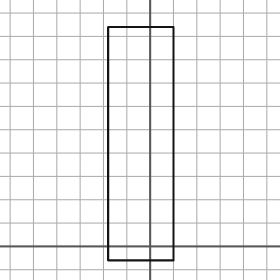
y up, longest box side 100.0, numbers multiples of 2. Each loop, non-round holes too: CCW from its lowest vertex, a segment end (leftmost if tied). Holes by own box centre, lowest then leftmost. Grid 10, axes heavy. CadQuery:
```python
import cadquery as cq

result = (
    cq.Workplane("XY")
    .moveTo(-18.0, -6.0)
    .lineTo(10.0, -6.0)
    .lineTo(10.0, 94.0)
    .lineTo(-18.0, 94.0)
    .close()
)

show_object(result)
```